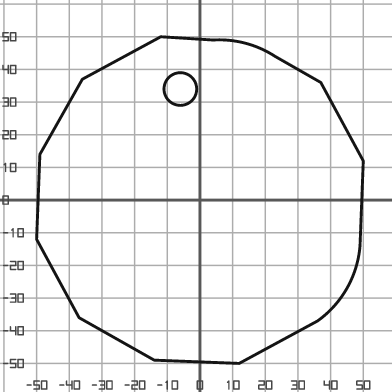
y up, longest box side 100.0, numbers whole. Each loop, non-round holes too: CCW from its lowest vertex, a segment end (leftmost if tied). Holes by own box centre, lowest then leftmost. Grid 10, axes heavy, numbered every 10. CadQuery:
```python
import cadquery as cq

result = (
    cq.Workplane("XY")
    .moveTo(12.0, -50.0)
    .lineTo(36.0, -37.0)
    .threePointArc((45.0, -27.0), (49.0, -14.0))
    .lineTo(50.0, 12.0)
    .lineTo(37.0, 36.0)
    .lineTo(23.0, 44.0)
    .threePointArc((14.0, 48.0), (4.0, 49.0))
    .lineTo(-12.0, 50.0)
    .lineTo(-36.0, 37.0)
    .lineTo(-49.0, 14.0)
    .lineTo(-50.0, -12.0)
    .lineTo(-37.0, -36.0)
    .lineTo(-14.0, -49.0)
    .close()
    .moveTo(-6.0, 34.0)
    .circle(5.0)
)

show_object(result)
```